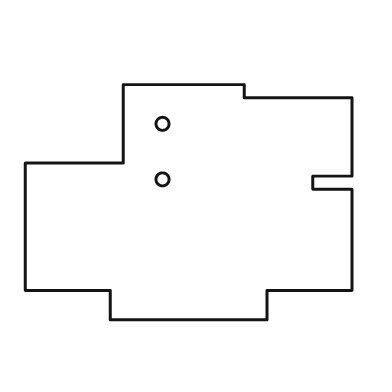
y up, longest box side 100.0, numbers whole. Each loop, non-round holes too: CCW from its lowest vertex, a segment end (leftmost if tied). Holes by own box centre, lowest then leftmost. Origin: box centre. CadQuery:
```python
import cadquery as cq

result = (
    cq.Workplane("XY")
    .moveTo(-24.0, -36.0)
    .lineTo(24.0, -36.0)
    .lineTo(24.0, -27.0)
    .lineTo(50.0, -27.0)
    .lineTo(50.0, 4.0)
    .lineTo(38.0, 4.0)
    .lineTo(38.0, 8.0)
    .lineTo(50.0, 8.0)
    .lineTo(50.0, 32.0)
    .lineTo(17.0, 32.0)
    .lineTo(17.0, 36.0)
    .lineTo(-20.0, 36.0)
    .lineTo(-20.0, 12.0)
    .lineTo(-50.0, 12.0)
    .lineTo(-50.0, -27.0)
    .lineTo(-24.0, -27.0)
    .close()
    .moveTo(-8.0, 7.0)
    .circle(2.0)
    .moveTo(-8.0, 24.0)
    .circle(2.0)
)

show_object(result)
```